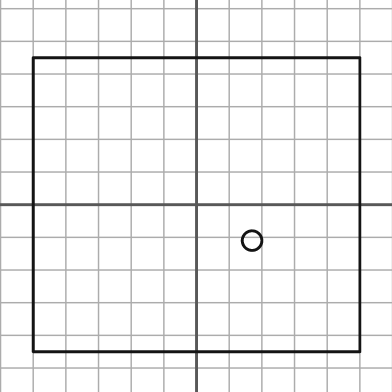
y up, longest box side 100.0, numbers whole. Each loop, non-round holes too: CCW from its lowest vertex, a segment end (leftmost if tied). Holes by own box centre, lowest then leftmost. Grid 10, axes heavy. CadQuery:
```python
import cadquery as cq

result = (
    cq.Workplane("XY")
    .moveTo(-50.0, -45.0)
    .lineTo(50.0, -45.0)
    .lineTo(50.0, 45.0)
    .lineTo(-50.0, 45.0)
    .close()
    .moveTo(17.0, -11.0)
    .circle(3.0)
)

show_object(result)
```